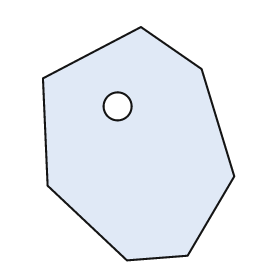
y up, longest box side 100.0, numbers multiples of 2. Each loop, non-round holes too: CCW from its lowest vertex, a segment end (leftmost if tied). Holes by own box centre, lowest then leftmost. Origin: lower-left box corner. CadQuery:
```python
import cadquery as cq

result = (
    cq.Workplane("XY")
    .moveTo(36.0, 0.0)
    .lineTo(62.0, 2.0)
    .lineTo(82.0, 36.0)
    .lineTo(68.0, 82.0)
    .lineTo(42.0, 100.0)
    .lineTo(0.0, 78.0)
    .lineTo(2.0, 32.0)
    .close()
    .moveTo(32.0, 66.0)
    .circle(6.0)
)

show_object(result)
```